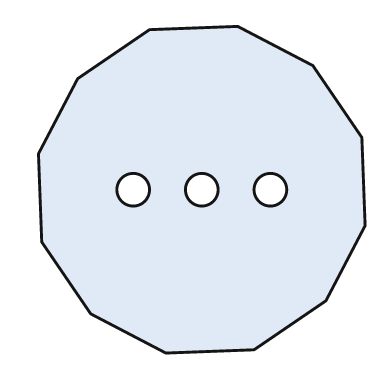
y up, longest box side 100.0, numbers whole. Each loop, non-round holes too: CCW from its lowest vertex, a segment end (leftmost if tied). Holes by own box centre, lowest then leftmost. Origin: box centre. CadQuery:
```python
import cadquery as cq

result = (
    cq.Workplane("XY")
    .moveTo(-11.0, -50.0)
    .lineTo(16.0, -49.0)
    .lineTo(38.0, -34.0)
    .lineTo(50.0, -11.0)
    .lineTo(49.0, 16.0)
    .lineTo(34.0, 38.0)
    .lineTo(11.0, 50.0)
    .lineTo(-16.0, 49.0)
    .lineTo(-38.0, 34.0)
    .lineTo(-50.0, 11.0)
    .lineTo(-49.0, -16.0)
    .lineTo(-34.0, -38.0)
    .close()
    .moveTo(-21.0, 0.0)
    .circle(5.0)
    .moveTo(0.0, 0.0)
    .circle(5.0)
    .moveTo(21.0, 0.0)
    .circle(5.0)
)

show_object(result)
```